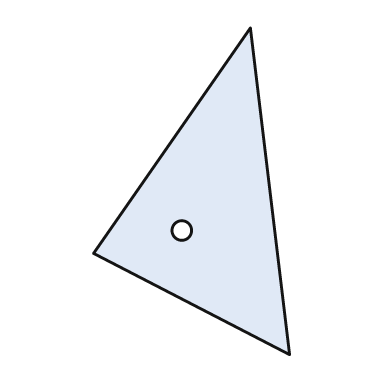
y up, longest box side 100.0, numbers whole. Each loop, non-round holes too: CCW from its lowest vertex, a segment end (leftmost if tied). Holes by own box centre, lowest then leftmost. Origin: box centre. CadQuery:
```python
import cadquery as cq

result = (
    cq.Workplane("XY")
    .moveTo(30.0, -50.0)
    .lineTo(18.0, 50.0)
    .lineTo(-30.0, -19.0)
    .close()
    .moveTo(-3.0, -12.0)
    .circle(3.0)
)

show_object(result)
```